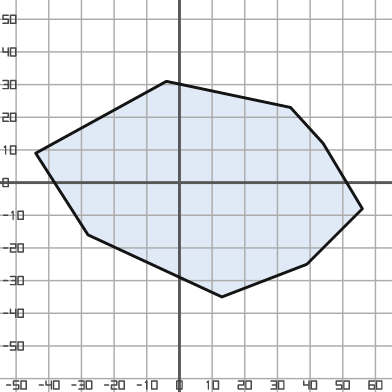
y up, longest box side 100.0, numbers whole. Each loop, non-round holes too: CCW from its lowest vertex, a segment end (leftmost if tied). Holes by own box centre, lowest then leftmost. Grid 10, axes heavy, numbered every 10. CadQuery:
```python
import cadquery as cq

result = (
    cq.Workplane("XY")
    .moveTo(13.0, -35.0)
    .lineTo(39.0, -25.0)
    .lineTo(56.0, -8.0)
    .lineTo(44.0, 12.0)
    .lineTo(34.0, 23.0)
    .lineTo(-4.0, 31.0)
    .lineTo(-44.0, 9.0)
    .lineTo(-28.0, -16.0)
    .close()
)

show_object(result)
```